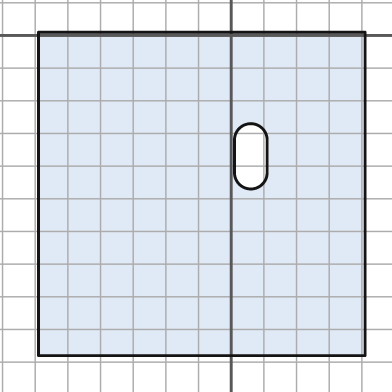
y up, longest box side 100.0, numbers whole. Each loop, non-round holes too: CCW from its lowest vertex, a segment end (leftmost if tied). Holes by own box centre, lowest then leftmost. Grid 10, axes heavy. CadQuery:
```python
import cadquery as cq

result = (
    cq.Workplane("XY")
    .moveTo(-59.0, -98.0)
    .lineTo(41.0, -98.0)
    .lineTo(41.0, 1.0)
    .lineTo(-59.0, 1.0)
    .close()
    .moveTo(1.0, -42.0)
    .threePointArc((6.0, -47.0), (11.0, -42.0))
    .lineTo(11.0, -32.0)
    .threePointArc((6.0, -27.0), (1.0, -32.0))
    .close()
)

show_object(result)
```